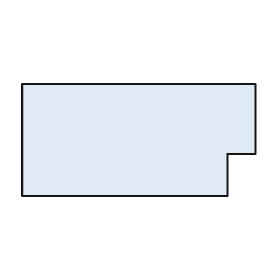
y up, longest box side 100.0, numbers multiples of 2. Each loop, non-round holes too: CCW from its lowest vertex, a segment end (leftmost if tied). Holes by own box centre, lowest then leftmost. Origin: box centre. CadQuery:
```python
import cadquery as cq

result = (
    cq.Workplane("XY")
    .moveTo(-50.0, -24.0)
    .lineTo(38.0, -24.0)
    .lineTo(38.0, -6.0)
    .lineTo(50.0, -6.0)
    .lineTo(50.0, 24.0)
    .lineTo(-50.0, 24.0)
    .close()
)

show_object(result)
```